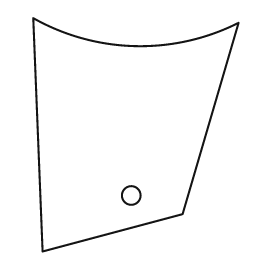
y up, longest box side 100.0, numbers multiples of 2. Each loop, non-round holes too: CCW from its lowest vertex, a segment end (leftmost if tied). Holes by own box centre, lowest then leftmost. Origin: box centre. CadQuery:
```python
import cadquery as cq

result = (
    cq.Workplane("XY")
    .moveTo(-40.0, -50.0)
    .lineTo(20.0, -34.0)
    .lineTo(44.0, 48.0)
    .threePointArc((0.0, 38.0), (-44.0, 50.0))
    .close()
    .moveTo(-2.0, -26.0)
    .circle(4.0)
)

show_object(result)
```